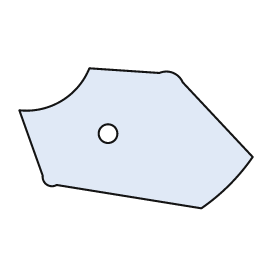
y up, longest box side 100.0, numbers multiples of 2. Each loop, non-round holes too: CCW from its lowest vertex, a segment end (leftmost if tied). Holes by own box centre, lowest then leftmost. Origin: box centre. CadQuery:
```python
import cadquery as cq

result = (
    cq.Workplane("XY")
    .moveTo(28.0, -30.0)
    .threePointArc((40.0, -20.0), (50.0, -8.0))
    .lineTo(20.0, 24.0)
    .threePointArc((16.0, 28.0), (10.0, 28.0))
    .lineTo(-20.0, 30.0)
    .threePointArc((-32.0, 16.0), (-50.0, 12.0))
    .lineTo(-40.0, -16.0)
    .threePointArc((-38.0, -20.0), (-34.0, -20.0))
    .close()
    .moveTo(-12.0, 2.0)
    .circle(4.0)
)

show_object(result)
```